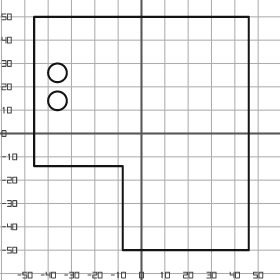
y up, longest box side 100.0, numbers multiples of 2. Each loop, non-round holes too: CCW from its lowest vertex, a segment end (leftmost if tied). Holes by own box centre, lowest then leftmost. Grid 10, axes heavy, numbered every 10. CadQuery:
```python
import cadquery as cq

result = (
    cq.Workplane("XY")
    .moveTo(-8.0, -50.0)
    .lineTo(46.0, -50.0)
    .lineTo(46.0, 50.0)
    .lineTo(-46.0, 50.0)
    .lineTo(-46.0, -14.0)
    .lineTo(-8.0, -14.0)
    .close()
    .moveTo(-36.0, 14.0)
    .circle(4.0)
    .moveTo(-36.0, 26.0)
    .circle(4.0)
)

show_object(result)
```